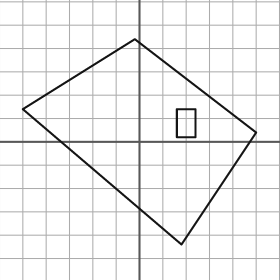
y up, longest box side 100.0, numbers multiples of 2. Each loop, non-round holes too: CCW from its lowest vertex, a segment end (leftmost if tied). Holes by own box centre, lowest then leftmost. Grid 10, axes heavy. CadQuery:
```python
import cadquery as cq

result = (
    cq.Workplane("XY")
    .moveTo(18.0, -44.0)
    .lineTo(50.0, 4.0)
    .lineTo(-2.0, 44.0)
    .lineTo(-50.0, 14.0)
    .close()
    .moveTo(16.0, 2.0)
    .lineTo(24.0, 2.0)
    .lineTo(24.0, 14.0)
    .lineTo(16.0, 14.0)
    .close()
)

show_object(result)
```